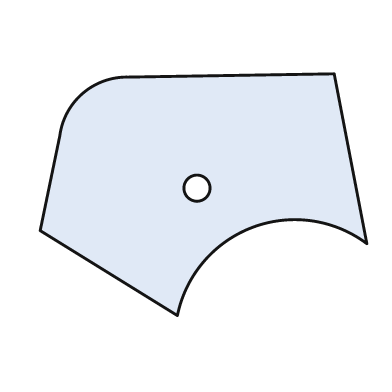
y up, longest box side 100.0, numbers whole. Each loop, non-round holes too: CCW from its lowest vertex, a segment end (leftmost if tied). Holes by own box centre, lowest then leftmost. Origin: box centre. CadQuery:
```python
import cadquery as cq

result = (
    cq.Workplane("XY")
    .moveTo(-8.0, -37.0)
    .threePointArc((15.0, -10.0), (50.0, -15.0))
    .lineTo(40.0, 37.0)
    .lineTo(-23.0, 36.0)
    .threePointArc((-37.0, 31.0), (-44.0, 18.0))
    .lineTo(-50.0, -11.0)
    .close()
    .moveTo(-2.0, 2.0)
    .circle(4.0)
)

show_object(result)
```